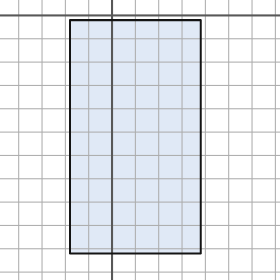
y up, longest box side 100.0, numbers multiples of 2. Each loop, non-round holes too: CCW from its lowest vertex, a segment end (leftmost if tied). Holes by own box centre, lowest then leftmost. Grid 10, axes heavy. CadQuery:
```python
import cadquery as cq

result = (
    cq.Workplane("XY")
    .moveTo(-18.0, -102.0)
    .lineTo(38.0, -102.0)
    .lineTo(38.0, -2.0)
    .lineTo(-18.0, -2.0)
    .close()
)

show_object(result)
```